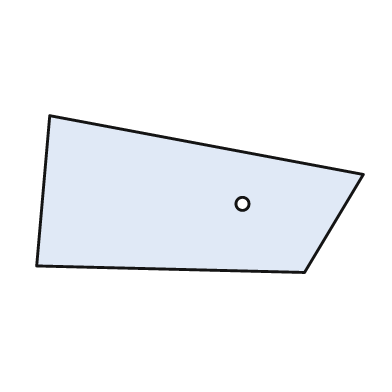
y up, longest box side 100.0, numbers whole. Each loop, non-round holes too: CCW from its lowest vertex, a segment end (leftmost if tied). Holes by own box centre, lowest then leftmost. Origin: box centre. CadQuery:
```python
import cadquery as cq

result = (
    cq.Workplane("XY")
    .moveTo(32.0, -24.0)
    .lineTo(50.0, 6.0)
    .lineTo(-46.0, 24.0)
    .lineTo(-50.0, -22.0)
    .close()
    .moveTo(13.0, -3.0)
    .circle(2.0)
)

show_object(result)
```